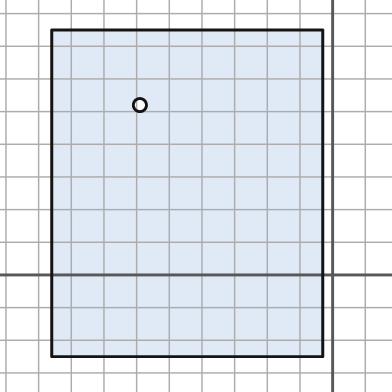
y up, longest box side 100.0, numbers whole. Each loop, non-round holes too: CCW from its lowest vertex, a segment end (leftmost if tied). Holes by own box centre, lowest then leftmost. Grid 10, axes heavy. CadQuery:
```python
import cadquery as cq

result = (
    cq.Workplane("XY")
    .moveTo(-86.0, -25.0)
    .lineTo(-3.0, -25.0)
    .lineTo(-3.0, 75.0)
    .lineTo(-86.0, 75.0)
    .close()
    .moveTo(-59.0, 52.0)
    .circle(2.0)
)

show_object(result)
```